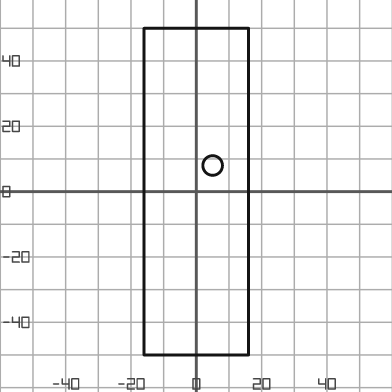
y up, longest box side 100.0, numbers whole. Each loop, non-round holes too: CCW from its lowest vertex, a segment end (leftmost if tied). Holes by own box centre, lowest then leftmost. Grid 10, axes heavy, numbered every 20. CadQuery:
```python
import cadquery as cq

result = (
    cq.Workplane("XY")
    .moveTo(-16.0, -50.0)
    .lineTo(16.0, -50.0)
    .lineTo(16.0, 50.0)
    .lineTo(-16.0, 50.0)
    .close()
    .moveTo(5.0, 8.0)
    .circle(3.0)
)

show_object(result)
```